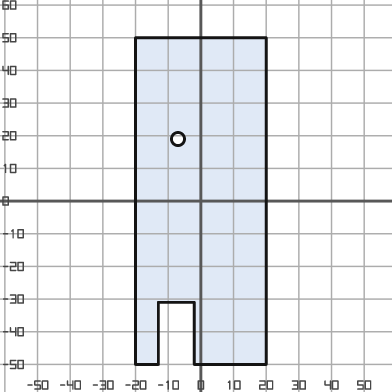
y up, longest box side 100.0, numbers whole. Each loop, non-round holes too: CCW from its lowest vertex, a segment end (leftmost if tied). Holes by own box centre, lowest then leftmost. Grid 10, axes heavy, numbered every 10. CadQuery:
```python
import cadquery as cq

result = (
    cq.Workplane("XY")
    .moveTo(-20.0, -50.0)
    .lineTo(-13.0, -50.0)
    .lineTo(-13.0, -31.0)
    .lineTo(-2.0, -31.0)
    .lineTo(-2.0, -50.0)
    .lineTo(20.0, -50.0)
    .lineTo(20.0, 50.0)
    .lineTo(-20.0, 50.0)
    .close()
    .moveTo(-7.0, 19.0)
    .circle(2.0)
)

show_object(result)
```